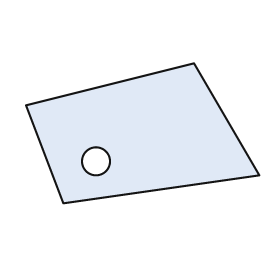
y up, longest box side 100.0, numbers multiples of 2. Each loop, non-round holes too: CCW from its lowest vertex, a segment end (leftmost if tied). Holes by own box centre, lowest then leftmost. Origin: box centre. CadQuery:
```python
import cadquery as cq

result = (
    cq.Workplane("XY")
    .moveTo(-34.0, -30.0)
    .lineTo(50.0, -18.0)
    .lineTo(22.0, 30.0)
    .lineTo(-50.0, 12.0)
    .close()
    .moveTo(-20.0, -12.0)
    .circle(6.0)
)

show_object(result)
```